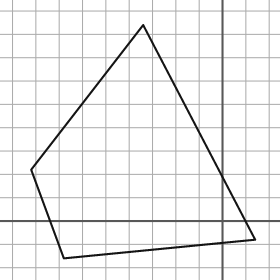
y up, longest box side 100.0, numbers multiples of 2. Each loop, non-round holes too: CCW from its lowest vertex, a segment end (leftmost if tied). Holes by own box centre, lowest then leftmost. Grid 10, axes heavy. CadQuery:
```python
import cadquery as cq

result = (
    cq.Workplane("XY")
    .moveTo(-68.0, -16.0)
    .lineTo(14.0, -8.0)
    .lineTo(-34.0, 84.0)
    .lineTo(-82.0, 22.0)
    .close()
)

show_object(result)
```